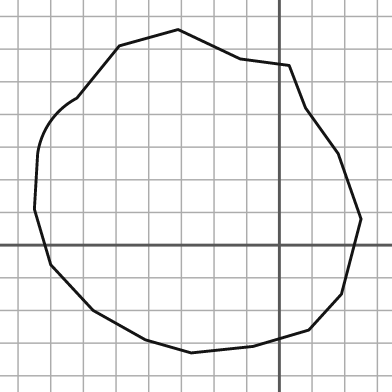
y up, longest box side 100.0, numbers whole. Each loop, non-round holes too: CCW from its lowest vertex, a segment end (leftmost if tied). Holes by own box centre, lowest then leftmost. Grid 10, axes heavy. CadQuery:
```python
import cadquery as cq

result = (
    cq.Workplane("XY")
    .moveTo(-27.0, -33.0)
    .lineTo(-8.0, -31.0)
    .lineTo(9.0, -26.0)
    .lineTo(19.0, -15.0)
    .lineTo(25.0, 8.0)
    .lineTo(18.0, 28.0)
    .lineTo(8.0, 42.0)
    .lineTo(3.0, 55.0)
    .lineTo(-12.0, 57.0)
    .lineTo(-31.0, 66.0)
    .lineTo(-49.0, 61.0)
    .lineTo(-62.0, 45.0)
    .threePointArc((-70.0, 38.0), (-74.0, 28.0))
    .lineTo(-75.0, 11.0)
    .lineTo(-70.0, -6.0)
    .lineTo(-57.0, -20.0)
    .lineTo(-41.0, -29.0)
    .close()
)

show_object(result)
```